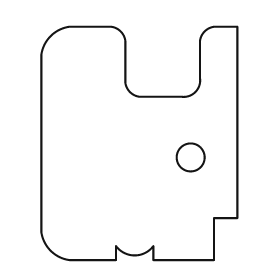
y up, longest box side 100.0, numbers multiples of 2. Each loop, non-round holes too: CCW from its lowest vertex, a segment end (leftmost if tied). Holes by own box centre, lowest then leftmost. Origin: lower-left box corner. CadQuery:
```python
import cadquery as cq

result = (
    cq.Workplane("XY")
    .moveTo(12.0, 0.0)
    .lineTo(32.0, 0.0)
    .lineTo(32.0, 6.0)
    .threePointArc((40.0, 2.0), (48.0, 6.0))
    .lineTo(48.0, 0.0)
    .lineTo(74.0, 0.0)
    .lineTo(74.0, 18.0)
    .lineTo(84.0, 18.0)
    .lineTo(84.0, 100.0)
    .lineTo(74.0, 100.0)
    .threePointArc((70.0, 98.0), (68.0, 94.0))
    .lineTo(68.0, 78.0)
    .threePointArc((66.0, 72.0), (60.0, 70.0))
    .lineTo(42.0, 70.0)
    .threePointArc((38.0, 72.0), (36.0, 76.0))
    .lineTo(36.0, 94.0)
    .threePointArc((34.0, 98.0), (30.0, 100.0))
    .lineTo(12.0, 100.0)
    .threePointArc((4.0, 96.0), (0.0, 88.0))
    .lineTo(0.0, 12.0)
    .threePointArc((4.0, 4.0), (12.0, 0.0))
    .close()
    .moveTo(64.0, 44.0)
    .circle(6.0)
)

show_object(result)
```